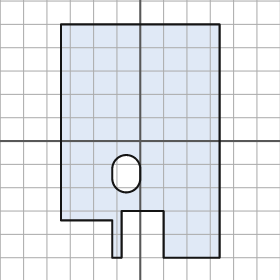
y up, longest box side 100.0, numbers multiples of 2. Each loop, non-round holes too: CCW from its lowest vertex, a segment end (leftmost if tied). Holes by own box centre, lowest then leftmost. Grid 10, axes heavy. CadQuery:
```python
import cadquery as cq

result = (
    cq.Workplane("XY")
    .moveTo(-12.0, -50.0)
    .lineTo(-8.0, -50.0)
    .lineTo(-8.0, -30.0)
    .lineTo(10.0, -30.0)
    .lineTo(10.0, -50.0)
    .lineTo(34.0, -50.0)
    .lineTo(34.0, 50.0)
    .lineTo(-34.0, 50.0)
    .lineTo(-34.0, -34.0)
    .lineTo(-12.0, -34.0)
    .close()
    .moveTo(-12.0, -16.0)
    .threePointArc((-6.0, -22.0), (0.0, -16.0))
    .lineTo(0.0, -12.0)
    .threePointArc((-6.0, -6.0), (-12.0, -12.0))
    .close()
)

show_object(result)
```